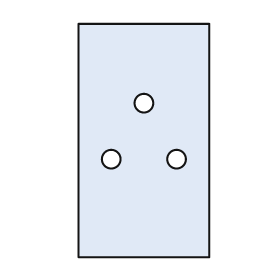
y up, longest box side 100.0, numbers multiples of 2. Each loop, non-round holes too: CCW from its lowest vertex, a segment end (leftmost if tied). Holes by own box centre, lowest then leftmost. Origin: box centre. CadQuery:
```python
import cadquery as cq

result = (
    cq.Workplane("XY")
    .moveTo(-28.0, -50.0)
    .lineTo(28.0, -50.0)
    .lineTo(28.0, 50.0)
    .lineTo(-28.0, 50.0)
    .close()
    .moveTo(-14.0, -8.0)
    .circle(4.0)
    .moveTo(14.0, -8.0)
    .circle(4.0)
    .moveTo(0.0, 16.0)
    .circle(4.0)
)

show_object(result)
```